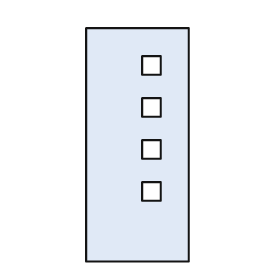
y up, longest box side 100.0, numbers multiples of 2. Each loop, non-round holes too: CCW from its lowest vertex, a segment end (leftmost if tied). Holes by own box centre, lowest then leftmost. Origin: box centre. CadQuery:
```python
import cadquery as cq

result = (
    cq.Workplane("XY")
    .moveTo(-22.0, -50.0)
    .lineTo(22.0, -50.0)
    .lineTo(22.0, 50.0)
    .lineTo(-22.0, 50.0)
    .close()
    .moveTo(2.0, -24.0)
    .lineTo(10.0, -24.0)
    .lineTo(10.0, -16.0)
    .lineTo(2.0, -16.0)
    .close()
    .moveTo(2.0, -6.0)
    .lineTo(10.0, -6.0)
    .lineTo(10.0, 2.0)
    .lineTo(2.0, 2.0)
    .close()
    .moveTo(2.0, 12.0)
    .lineTo(10.0, 12.0)
    .lineTo(10.0, 20.0)
    .lineTo(2.0, 20.0)
    .close()
    .moveTo(2.0, 30.0)
    .lineTo(10.0, 30.0)
    .lineTo(10.0, 38.0)
    .lineTo(2.0, 38.0)
    .close()
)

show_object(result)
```